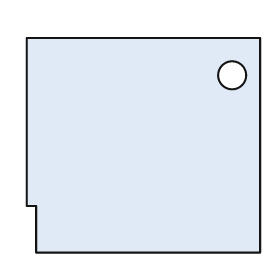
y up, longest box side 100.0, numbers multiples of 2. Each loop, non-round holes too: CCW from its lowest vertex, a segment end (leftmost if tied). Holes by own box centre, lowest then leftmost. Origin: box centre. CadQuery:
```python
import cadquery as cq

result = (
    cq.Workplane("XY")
    .moveTo(-46.0, -46.0)
    .lineTo(50.0, -46.0)
    .lineTo(50.0, 46.0)
    .lineTo(-50.0, 46.0)
    .lineTo(-50.0, -26.0)
    .lineTo(-46.0, -26.0)
    .close()
    .moveTo(38.0, 30.0)
    .circle(6.0)
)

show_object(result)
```